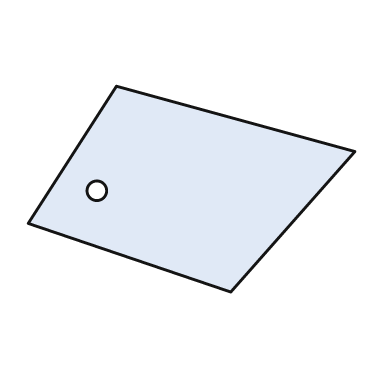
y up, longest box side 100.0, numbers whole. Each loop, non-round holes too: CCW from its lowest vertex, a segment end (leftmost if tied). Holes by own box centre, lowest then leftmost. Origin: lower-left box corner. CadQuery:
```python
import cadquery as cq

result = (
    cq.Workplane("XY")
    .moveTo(62.0, 0.0)
    .lineTo(100.0, 43.0)
    .lineTo(27.0, 63.0)
    .lineTo(0.0, 21.0)
    .close()
    .moveTo(21.0, 31.0)
    .circle(3.0)
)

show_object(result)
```